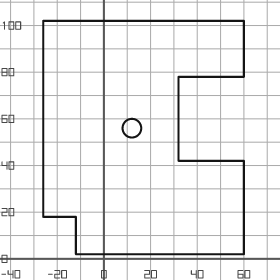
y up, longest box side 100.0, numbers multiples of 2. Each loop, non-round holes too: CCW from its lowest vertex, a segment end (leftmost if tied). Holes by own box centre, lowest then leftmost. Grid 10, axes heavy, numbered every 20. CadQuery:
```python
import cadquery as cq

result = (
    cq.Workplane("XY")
    .moveTo(-12.0, 2.0)
    .lineTo(60.0, 2.0)
    .lineTo(60.0, 42.0)
    .lineTo(32.0, 42.0)
    .lineTo(32.0, 78.0)
    .lineTo(60.0, 78.0)
    .lineTo(60.0, 102.0)
    .lineTo(-26.0, 102.0)
    .lineTo(-26.0, 18.0)
    .lineTo(-12.0, 18.0)
    .close()
    .moveTo(12.0, 56.0)
    .circle(4.0)
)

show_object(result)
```